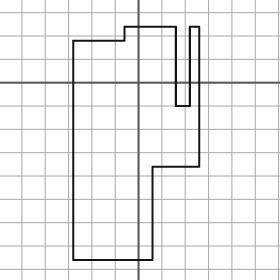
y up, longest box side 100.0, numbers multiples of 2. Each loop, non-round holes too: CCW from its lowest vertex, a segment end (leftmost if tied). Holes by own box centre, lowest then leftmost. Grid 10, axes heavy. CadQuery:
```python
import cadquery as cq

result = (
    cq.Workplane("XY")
    .moveTo(-28.0, -76.0)
    .lineTo(6.0, -76.0)
    .lineTo(6.0, -36.0)
    .lineTo(26.0, -36.0)
    .lineTo(26.0, 24.0)
    .lineTo(22.0, 24.0)
    .lineTo(22.0, -10.0)
    .lineTo(16.0, -10.0)
    .lineTo(16.0, 24.0)
    .lineTo(-6.0, 24.0)
    .lineTo(-6.0, 18.0)
    .lineTo(-28.0, 18.0)
    .close()
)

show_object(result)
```